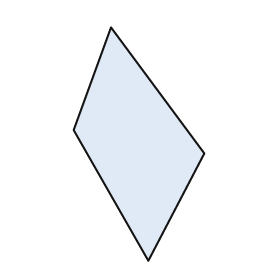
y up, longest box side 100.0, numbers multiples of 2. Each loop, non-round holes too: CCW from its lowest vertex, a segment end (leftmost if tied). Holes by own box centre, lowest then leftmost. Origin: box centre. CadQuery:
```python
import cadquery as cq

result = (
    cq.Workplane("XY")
    .moveTo(4.0, -50.0)
    .lineTo(28.0, -4.0)
    .lineTo(-12.0, 50.0)
    .lineTo(-28.0, 6.0)
    .close()
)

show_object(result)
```